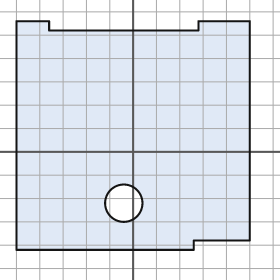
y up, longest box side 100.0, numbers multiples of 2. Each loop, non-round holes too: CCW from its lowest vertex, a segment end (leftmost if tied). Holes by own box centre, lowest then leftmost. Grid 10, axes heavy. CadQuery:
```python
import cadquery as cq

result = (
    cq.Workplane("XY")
    .moveTo(-50.0, -42.0)
    .lineTo(26.0, -42.0)
    .lineTo(26.0, -38.0)
    .lineTo(50.0, -38.0)
    .lineTo(50.0, 56.0)
    .lineTo(28.0, 56.0)
    .lineTo(28.0, 52.0)
    .lineTo(-36.0, 52.0)
    .lineTo(-36.0, 56.0)
    .lineTo(-50.0, 56.0)
    .close()
    .moveTo(-4.0, -22.0)
    .circle(8.0)
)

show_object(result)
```